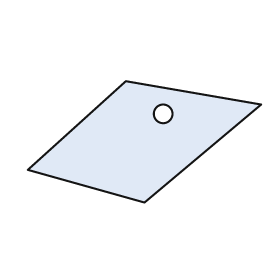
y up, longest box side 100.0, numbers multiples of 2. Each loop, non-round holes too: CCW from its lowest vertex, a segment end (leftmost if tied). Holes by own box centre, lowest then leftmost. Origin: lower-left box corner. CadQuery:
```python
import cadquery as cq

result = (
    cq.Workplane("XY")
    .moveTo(50.0, 0.0)
    .lineTo(100.0, 42.0)
    .lineTo(42.0, 52.0)
    .lineTo(0.0, 14.0)
    .close()
    .moveTo(58.0, 38.0)
    .circle(4.0)
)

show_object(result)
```